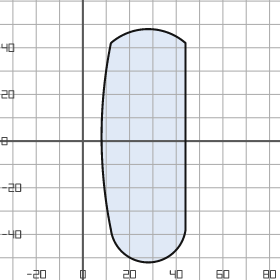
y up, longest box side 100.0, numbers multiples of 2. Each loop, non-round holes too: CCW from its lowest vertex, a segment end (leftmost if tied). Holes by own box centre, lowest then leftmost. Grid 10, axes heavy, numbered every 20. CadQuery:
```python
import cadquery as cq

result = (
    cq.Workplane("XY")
    .moveTo(12.0, -38.0)
    .threePointArc((28.0, -52.0), (44.0, -38.0))
    .lineTo(44.0, 42.0)
    .threePointArc((28.0, 48.0), (12.0, 42.0))
    .threePointArc((8.0, 2.0), (12.0, -38.0))
    .close()
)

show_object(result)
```